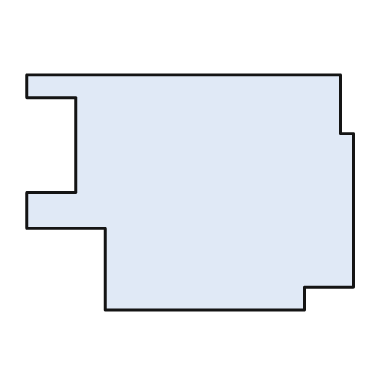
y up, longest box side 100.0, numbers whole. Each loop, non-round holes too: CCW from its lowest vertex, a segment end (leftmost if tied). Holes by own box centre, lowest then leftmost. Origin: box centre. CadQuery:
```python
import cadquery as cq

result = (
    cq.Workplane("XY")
    .moveTo(-26.0, -36.0)
    .lineTo(35.0, -36.0)
    .lineTo(35.0, -29.0)
    .lineTo(50.0, -29.0)
    .lineTo(50.0, 18.0)
    .lineTo(46.0, 18.0)
    .lineTo(46.0, 36.0)
    .lineTo(-50.0, 36.0)
    .lineTo(-50.0, 29.0)
    .lineTo(-35.0, 29.0)
    .lineTo(-35.0, 0.0)
    .lineTo(-50.0, 0.0)
    .lineTo(-50.0, -11.0)
    .lineTo(-26.0, -11.0)
    .close()
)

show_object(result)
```